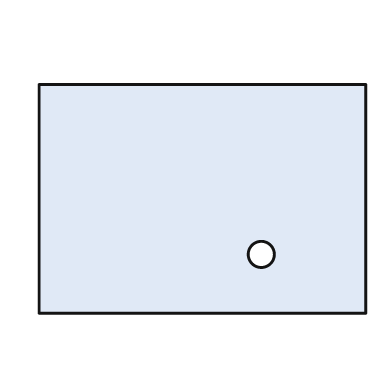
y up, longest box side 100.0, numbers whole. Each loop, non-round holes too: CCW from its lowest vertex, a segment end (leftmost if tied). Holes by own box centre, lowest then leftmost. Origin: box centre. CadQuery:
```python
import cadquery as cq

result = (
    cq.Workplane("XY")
    .moveTo(-50.0, -35.0)
    .lineTo(50.0, -35.0)
    .lineTo(50.0, 35.0)
    .lineTo(-50.0, 35.0)
    .close()
    .moveTo(18.0, -17.0)
    .circle(4.0)
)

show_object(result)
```